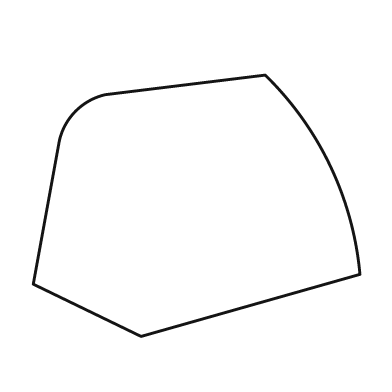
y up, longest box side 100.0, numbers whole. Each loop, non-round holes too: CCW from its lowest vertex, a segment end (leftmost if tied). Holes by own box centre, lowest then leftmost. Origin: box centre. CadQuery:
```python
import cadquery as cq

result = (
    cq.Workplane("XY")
    .moveTo(-17.0, -40.0)
    .lineTo(50.0, -21.0)
    .threePointArc((41.0, 12.0), (21.0, 40.0))
    .lineTo(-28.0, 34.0)
    .threePointArc((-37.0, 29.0), (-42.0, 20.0))
    .lineTo(-50.0, -24.0)
    .close()
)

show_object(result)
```